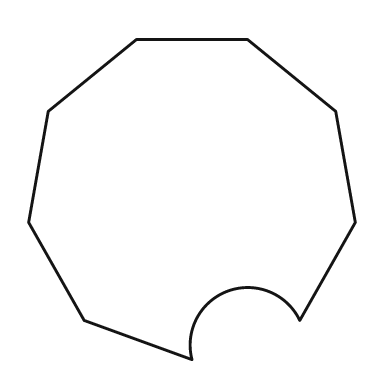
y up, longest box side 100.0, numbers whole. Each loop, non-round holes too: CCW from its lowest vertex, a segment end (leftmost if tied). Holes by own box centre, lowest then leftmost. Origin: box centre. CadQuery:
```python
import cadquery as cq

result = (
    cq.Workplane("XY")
    .moveTo(0.0, -49.0)
    .threePointArc((11.0, -28.0), (33.0, -37.0))
    .lineTo(50.0, -7.0)
    .lineTo(44.0, 27.0)
    .lineTo(17.0, 49.0)
    .lineTo(-17.0, 49.0)
    .lineTo(-44.0, 27.0)
    .lineTo(-50.0, -7.0)
    .lineTo(-33.0, -37.0)
    .close()
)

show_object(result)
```